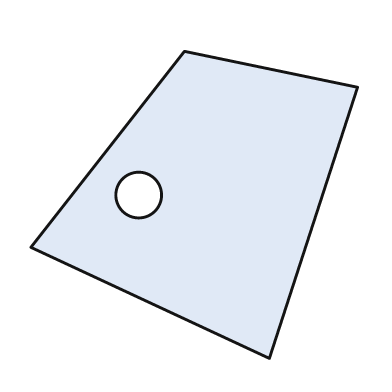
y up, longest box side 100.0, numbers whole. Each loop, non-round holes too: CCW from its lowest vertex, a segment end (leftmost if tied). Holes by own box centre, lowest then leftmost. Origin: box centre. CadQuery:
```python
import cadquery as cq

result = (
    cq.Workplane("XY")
    .moveTo(23.0, -47.0)
    .lineTo(50.0, 36.0)
    .lineTo(-3.0, 47.0)
    .lineTo(-50.0, -13.0)
    .close()
    .moveTo(-17.0, 3.0)
    .circle(7.0)
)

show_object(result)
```